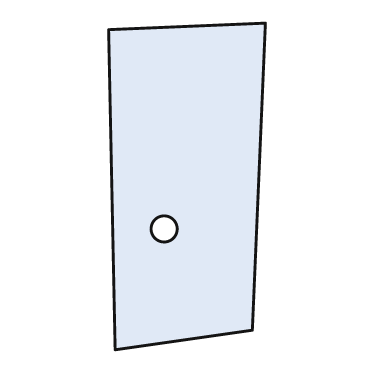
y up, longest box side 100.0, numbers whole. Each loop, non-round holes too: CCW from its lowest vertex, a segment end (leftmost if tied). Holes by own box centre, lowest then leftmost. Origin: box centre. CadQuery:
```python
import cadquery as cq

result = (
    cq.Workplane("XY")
    .moveTo(-22.0, -50.0)
    .lineTo(20.0, -44.0)
    .lineTo(24.0, 50.0)
    .lineTo(-24.0, 48.0)
    .close()
    .moveTo(-7.0, -13.0)
    .circle(4.0)
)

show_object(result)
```